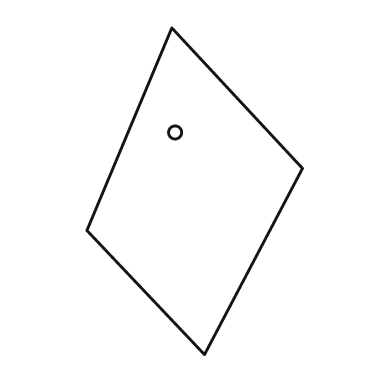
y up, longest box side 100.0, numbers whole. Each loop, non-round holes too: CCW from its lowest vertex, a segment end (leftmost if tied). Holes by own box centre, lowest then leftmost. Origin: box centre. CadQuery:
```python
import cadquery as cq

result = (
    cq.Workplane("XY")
    .moveTo(3.0, -50.0)
    .lineTo(33.0, 7.0)
    .lineTo(-7.0, 50.0)
    .lineTo(-33.0, -12.0)
    .close()
    .moveTo(-6.0, 18.0)
    .circle(2.0)
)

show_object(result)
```